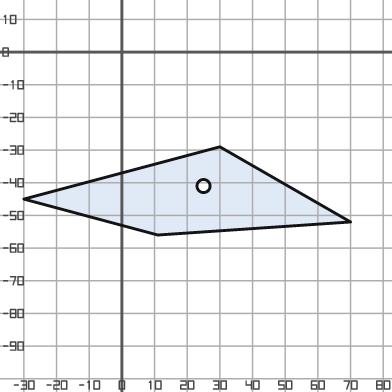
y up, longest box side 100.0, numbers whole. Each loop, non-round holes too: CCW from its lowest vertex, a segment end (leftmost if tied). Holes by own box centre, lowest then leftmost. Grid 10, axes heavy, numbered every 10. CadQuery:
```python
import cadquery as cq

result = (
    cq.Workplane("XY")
    .moveTo(11.0, -56.0)
    .lineTo(70.0, -52.0)
    .lineTo(30.0, -29.0)
    .lineTo(-30.0, -45.0)
    .close()
    .moveTo(25.0, -41.0)
    .circle(2.0)
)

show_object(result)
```